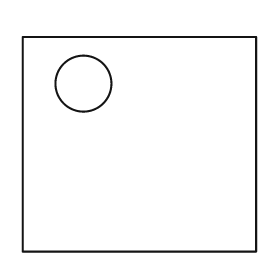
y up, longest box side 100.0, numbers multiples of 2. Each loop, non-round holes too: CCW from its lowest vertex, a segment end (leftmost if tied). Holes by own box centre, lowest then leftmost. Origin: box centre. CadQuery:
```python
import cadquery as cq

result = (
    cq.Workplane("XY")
    .moveTo(-50.0, -46.0)
    .lineTo(50.0, -46.0)
    .lineTo(50.0, 46.0)
    .lineTo(-50.0, 46.0)
    .close()
    .moveTo(-24.0, 26.0)
    .circle(12.0)
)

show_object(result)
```